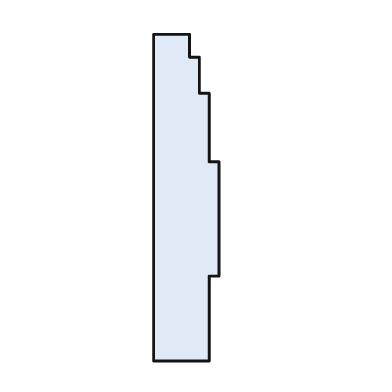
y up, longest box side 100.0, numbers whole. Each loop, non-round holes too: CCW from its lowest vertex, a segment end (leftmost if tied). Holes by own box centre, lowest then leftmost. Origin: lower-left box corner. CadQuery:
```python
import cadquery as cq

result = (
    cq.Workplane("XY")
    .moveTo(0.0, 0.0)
    .lineTo(17.0, 0.0)
    .lineTo(17.0, 26.0)
    .lineTo(20.0, 26.0)
    .lineTo(20.0, 61.0)
    .lineTo(17.0, 61.0)
    .lineTo(17.0, 82.0)
    .lineTo(14.0, 82.0)
    .lineTo(14.0, 93.0)
    .lineTo(11.0, 93.0)
    .lineTo(11.0, 100.0)
    .lineTo(0.0, 100.0)
    .close()
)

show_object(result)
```